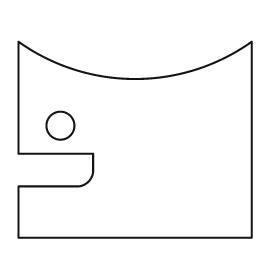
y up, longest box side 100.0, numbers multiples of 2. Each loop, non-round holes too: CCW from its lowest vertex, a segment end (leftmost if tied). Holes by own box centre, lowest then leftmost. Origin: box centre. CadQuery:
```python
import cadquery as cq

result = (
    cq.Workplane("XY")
    .moveTo(-50.0, -42.0)
    .lineTo(50.0, -42.0)
    .lineTo(50.0, 42.0)
    .threePointArc((0.0, 26.0), (-50.0, 42.0))
    .lineTo(-50.0, -6.0)
    .lineTo(-18.0, -6.0)
    .lineTo(-18.0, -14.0)
    .threePointArc((-20.0, -18.0), (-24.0, -20.0))
    .lineTo(-50.0, -20.0)
    .close()
    .moveTo(-32.0, 6.0)
    .circle(6.0)
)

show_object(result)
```